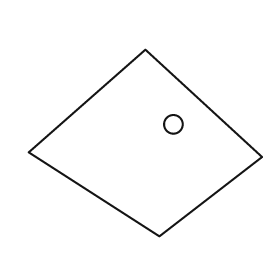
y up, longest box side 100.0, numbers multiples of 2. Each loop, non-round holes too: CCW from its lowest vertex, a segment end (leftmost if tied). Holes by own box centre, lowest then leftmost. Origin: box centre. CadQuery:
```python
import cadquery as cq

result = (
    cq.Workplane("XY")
    .moveTo(6.0, -40.0)
    .lineTo(50.0, -6.0)
    .lineTo(0.0, 40.0)
    .lineTo(-50.0, -4.0)
    .close()
    .moveTo(12.0, 8.0)
    .circle(4.0)
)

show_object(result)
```